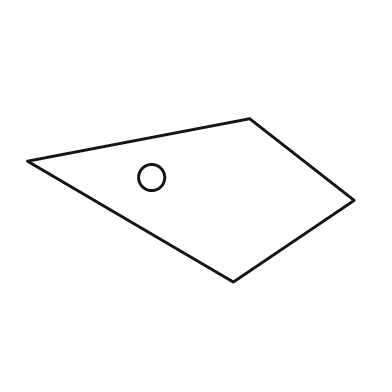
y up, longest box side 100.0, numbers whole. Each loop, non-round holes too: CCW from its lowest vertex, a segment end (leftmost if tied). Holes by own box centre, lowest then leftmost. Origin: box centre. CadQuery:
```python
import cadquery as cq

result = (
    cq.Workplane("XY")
    .moveTo(13.0, -25.0)
    .lineTo(50.0, 0.0)
    .lineTo(18.0, 25.0)
    .lineTo(-50.0, 12.0)
    .close()
    .moveTo(-12.0, 7.0)
    .circle(4.0)
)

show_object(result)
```